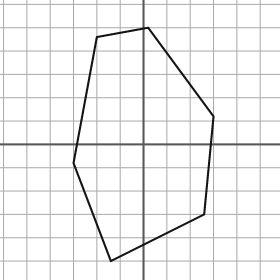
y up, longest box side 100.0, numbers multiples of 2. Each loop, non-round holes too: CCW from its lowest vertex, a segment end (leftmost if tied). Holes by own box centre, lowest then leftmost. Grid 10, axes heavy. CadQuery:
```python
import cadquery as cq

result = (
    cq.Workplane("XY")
    .moveTo(-14.0, -50.0)
    .lineTo(26.0, -30.0)
    .lineTo(30.0, 12.0)
    .lineTo(2.0, 50.0)
    .lineTo(-20.0, 46.0)
    .lineTo(-30.0, -8.0)
    .close()
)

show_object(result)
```